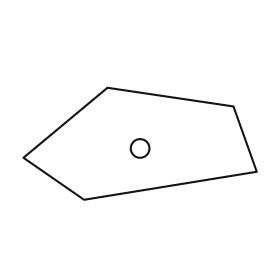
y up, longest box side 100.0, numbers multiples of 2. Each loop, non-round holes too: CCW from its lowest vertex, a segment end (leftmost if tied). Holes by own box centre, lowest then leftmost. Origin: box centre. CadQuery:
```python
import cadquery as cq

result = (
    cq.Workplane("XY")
    .moveTo(-24.0, -24.0)
    .lineTo(50.0, -12.0)
    .lineTo(40.0, 16.0)
    .lineTo(-14.0, 24.0)
    .lineTo(-50.0, -6.0)
    .close()
    .moveTo(0.0, -2.0)
    .circle(4.0)
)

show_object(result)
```